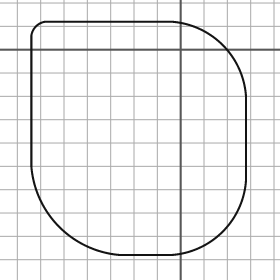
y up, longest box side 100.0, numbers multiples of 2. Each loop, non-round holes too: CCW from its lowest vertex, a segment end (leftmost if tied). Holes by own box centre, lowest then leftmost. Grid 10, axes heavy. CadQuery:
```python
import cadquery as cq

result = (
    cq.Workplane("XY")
    .moveTo(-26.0, -88.0)
    .lineTo(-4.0, -88.0)
    .threePointArc((18.0, -78.0), (28.0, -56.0))
    .lineTo(28.0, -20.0)
    .threePointArc((18.0, 2.0), (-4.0, 12.0))
    .lineTo(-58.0, 12.0)
    .threePointArc((-62.0, 10.0), (-64.0, 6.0))
    .lineTo(-64.0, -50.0)
    .threePointArc((-52.0, -76.0), (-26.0, -88.0))
    .close()
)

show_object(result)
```